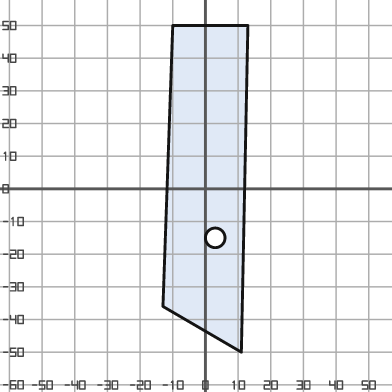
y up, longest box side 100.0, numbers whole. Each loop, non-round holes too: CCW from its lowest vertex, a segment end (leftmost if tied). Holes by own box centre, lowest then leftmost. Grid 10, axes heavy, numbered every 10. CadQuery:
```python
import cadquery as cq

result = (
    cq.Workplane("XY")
    .moveTo(11.0, -50.0)
    .lineTo(13.0, 50.0)
    .lineTo(-10.0, 50.0)
    .lineTo(-13.0, -36.0)
    .close()
    .moveTo(3.0, -15.0)
    .circle(3.0)
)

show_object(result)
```